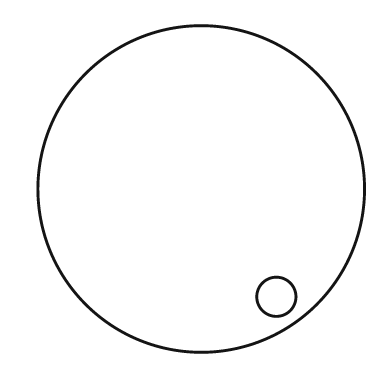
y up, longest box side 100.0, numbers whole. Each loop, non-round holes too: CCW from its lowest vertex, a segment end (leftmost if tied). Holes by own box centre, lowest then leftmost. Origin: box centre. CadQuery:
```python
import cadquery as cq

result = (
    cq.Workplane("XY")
    .moveTo(0.0, 0.0)
    .circle(50.0)
    .moveTo(23.0, -33.0)
    .circle(6.0)
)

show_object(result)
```